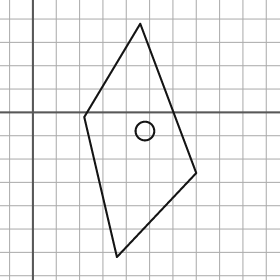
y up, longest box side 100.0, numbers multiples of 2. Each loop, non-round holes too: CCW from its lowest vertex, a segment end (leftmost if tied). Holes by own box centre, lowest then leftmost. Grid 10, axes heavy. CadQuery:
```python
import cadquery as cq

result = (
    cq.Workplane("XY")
    .moveTo(36.0, -62.0)
    .lineTo(70.0, -26.0)
    .lineTo(46.0, 38.0)
    .lineTo(22.0, -2.0)
    .close()
    .moveTo(48.0, -8.0)
    .circle(4.0)
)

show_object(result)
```